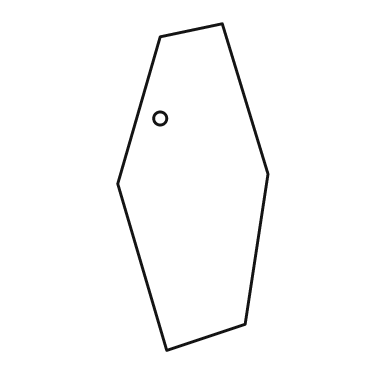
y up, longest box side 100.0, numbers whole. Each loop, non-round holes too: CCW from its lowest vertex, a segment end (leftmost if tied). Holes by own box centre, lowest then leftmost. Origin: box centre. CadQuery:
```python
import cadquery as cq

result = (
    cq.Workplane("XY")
    .moveTo(-8.0, -50.0)
    .lineTo(16.0, -42.0)
    .lineTo(23.0, 4.0)
    .lineTo(9.0, 50.0)
    .lineTo(-10.0, 46.0)
    .lineTo(-23.0, 1.0)
    .close()
    .moveTo(-10.0, 21.0)
    .circle(2.0)
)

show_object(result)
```